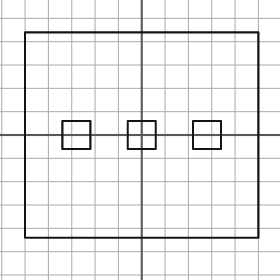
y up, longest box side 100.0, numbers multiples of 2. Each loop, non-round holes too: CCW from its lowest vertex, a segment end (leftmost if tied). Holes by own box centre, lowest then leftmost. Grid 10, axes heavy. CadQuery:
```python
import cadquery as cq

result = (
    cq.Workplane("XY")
    .moveTo(-50.0, -44.0)
    .lineTo(50.0, -44.0)
    .lineTo(50.0, 44.0)
    .lineTo(-50.0, 44.0)
    .close()
    .moveTo(-34.0, -6.0)
    .lineTo(-22.0, -6.0)
    .lineTo(-22.0, 6.0)
    .lineTo(-34.0, 6.0)
    .close()
    .moveTo(-6.0, -6.0)
    .lineTo(6.0, -6.0)
    .lineTo(6.0, 6.0)
    .lineTo(-6.0, 6.0)
    .close()
    .moveTo(22.0, -6.0)
    .lineTo(34.0, -6.0)
    .lineTo(34.0, 6.0)
    .lineTo(22.0, 6.0)
    .close()
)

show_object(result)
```